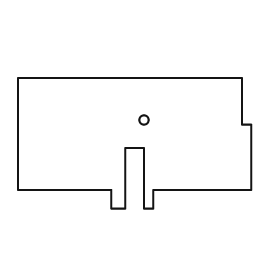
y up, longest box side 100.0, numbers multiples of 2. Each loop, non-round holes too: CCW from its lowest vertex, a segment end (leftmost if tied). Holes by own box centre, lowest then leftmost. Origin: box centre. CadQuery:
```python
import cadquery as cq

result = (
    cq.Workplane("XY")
    .moveTo(-10.0, -28.0)
    .lineTo(-4.0, -28.0)
    .lineTo(-4.0, -2.0)
    .lineTo(4.0, -2.0)
    .lineTo(4.0, -28.0)
    .lineTo(8.0, -28.0)
    .lineTo(8.0, -20.0)
    .lineTo(50.0, -20.0)
    .lineTo(50.0, 8.0)
    .lineTo(46.0, 8.0)
    .lineTo(46.0, 28.0)
    .lineTo(-50.0, 28.0)
    .lineTo(-50.0, -20.0)
    .lineTo(-10.0, -20.0)
    .close()
    .moveTo(4.0, 10.0)
    .circle(2.0)
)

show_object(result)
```